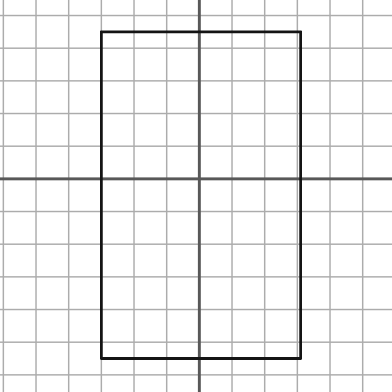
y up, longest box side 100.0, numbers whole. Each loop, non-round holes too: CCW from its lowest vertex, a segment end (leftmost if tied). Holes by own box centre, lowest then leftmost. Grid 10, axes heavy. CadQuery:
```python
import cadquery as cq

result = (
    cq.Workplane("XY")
    .moveTo(-30.0, -55.0)
    .lineTo(31.0, -55.0)
    .lineTo(31.0, 45.0)
    .lineTo(-30.0, 45.0)
    .close()
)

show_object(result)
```